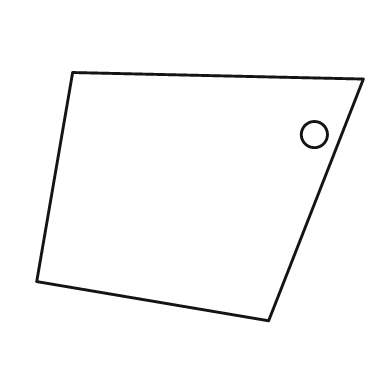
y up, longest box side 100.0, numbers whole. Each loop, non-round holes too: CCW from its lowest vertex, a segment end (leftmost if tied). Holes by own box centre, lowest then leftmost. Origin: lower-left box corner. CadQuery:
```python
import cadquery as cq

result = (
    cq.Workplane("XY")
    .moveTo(71.0, 0.0)
    .lineTo(100.0, 74.0)
    .lineTo(11.0, 76.0)
    .lineTo(0.0, 12.0)
    .close()
    .moveTo(85.0, 57.0)
    .circle(4.0)
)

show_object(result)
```